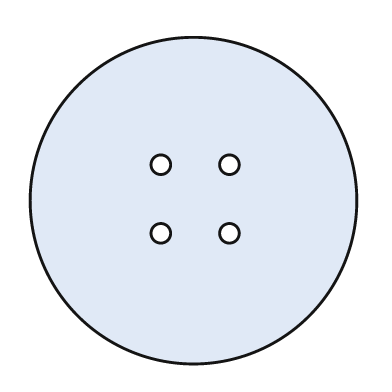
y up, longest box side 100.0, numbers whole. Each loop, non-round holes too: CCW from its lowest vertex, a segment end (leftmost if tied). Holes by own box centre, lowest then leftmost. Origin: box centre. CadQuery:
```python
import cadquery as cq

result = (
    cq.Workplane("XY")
    .moveTo(0.0, 0.0)
    .circle(50.0)
    .moveTo(-10.0, -10.0)
    .circle(3.0)
    .moveTo(11.0, -10.0)
    .circle(3.0)
    .moveTo(-10.0, 11.0)
    .circle(3.0)
    .moveTo(11.0, 11.0)
    .circle(3.0)
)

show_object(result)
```